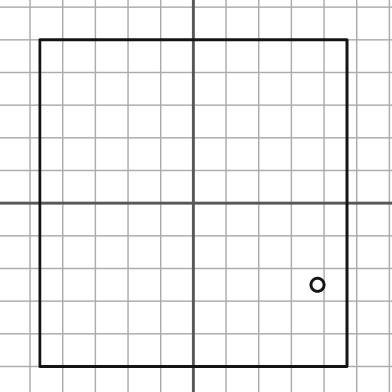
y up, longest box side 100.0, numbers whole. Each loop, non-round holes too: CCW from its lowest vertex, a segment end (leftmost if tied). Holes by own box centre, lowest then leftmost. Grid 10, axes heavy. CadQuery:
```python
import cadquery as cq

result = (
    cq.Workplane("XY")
    .moveTo(-47.0, -50.0)
    .lineTo(47.0, -50.0)
    .lineTo(47.0, 50.0)
    .lineTo(-47.0, 50.0)
    .close()
    .moveTo(38.0, -25.0)
    .circle(2.0)
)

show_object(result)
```